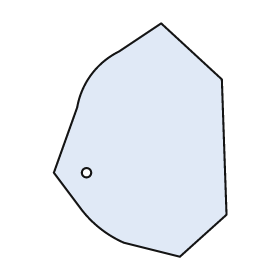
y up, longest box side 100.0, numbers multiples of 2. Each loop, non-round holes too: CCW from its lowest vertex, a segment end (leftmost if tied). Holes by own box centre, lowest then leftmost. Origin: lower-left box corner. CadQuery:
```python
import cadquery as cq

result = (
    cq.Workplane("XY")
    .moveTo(54.0, 0.0)
    .lineTo(74.0, 18.0)
    .lineTo(72.0, 76.0)
    .lineTo(46.0, 100.0)
    .lineTo(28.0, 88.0)
    .threePointArc((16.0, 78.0), (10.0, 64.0))
    .lineTo(0.0, 36.0)
    .lineTo(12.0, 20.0)
    .threePointArc((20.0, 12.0), (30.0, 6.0))
    .close()
    .moveTo(14.0, 36.0)
    .circle(2.0)
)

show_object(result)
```